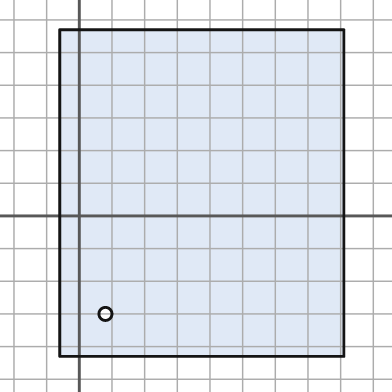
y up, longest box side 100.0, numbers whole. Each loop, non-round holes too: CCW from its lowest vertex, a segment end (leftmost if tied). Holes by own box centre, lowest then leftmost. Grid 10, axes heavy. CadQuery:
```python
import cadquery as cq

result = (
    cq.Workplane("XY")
    .moveTo(-6.0, -43.0)
    .lineTo(81.0, -43.0)
    .lineTo(81.0, 57.0)
    .lineTo(-6.0, 57.0)
    .close()
    .moveTo(8.0, -30.0)
    .circle(2.0)
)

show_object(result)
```